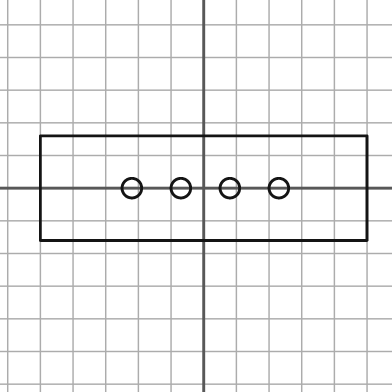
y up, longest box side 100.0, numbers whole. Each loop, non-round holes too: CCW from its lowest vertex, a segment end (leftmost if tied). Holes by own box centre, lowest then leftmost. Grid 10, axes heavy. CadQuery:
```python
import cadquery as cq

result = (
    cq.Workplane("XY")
    .moveTo(-50.0, -16.0)
    .lineTo(50.0, -16.0)
    .lineTo(50.0, 16.0)
    .lineTo(-50.0, 16.0)
    .close()
    .moveTo(-22.0, 0.0)
    .circle(3.0)
    .moveTo(-7.0, 0.0)
    .circle(3.0)
    .moveTo(8.0, 0.0)
    .circle(3.0)
    .moveTo(23.0, 0.0)
    .circle(3.0)
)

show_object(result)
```